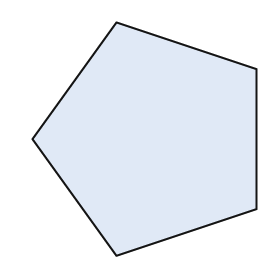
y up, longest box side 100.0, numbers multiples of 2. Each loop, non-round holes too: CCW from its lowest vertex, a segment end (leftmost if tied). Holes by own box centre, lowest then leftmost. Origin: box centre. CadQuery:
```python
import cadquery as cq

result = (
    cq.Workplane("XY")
    .moveTo(-12.0, -50.0)
    .lineTo(48.0, -30.0)
    .lineTo(48.0, 30.0)
    .lineTo(-12.0, 50.0)
    .lineTo(-48.0, 0.0)
    .close()
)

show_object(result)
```